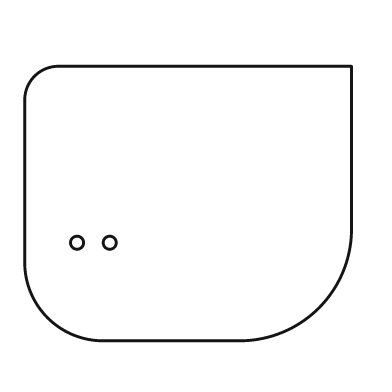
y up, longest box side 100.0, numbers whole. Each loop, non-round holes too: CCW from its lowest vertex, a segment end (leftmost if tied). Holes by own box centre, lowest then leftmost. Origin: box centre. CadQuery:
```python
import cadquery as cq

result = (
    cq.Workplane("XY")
    .moveTo(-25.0, -42.0)
    .lineTo(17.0, -42.0)
    .threePointArc((40.0, -32.0), (50.0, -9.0))
    .lineTo(50.0, 42.0)
    .lineTo(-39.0, 42.0)
    .threePointArc((-47.0, 39.0), (-50.0, 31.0))
    .lineTo(-50.0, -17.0)
    .threePointArc((-43.0, -35.0), (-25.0, -42.0))
    .close()
    .moveTo(-34.0, -12.0)
    .circle(2.0)
    .moveTo(-24.0, -12.0)
    .circle(2.0)
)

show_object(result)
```